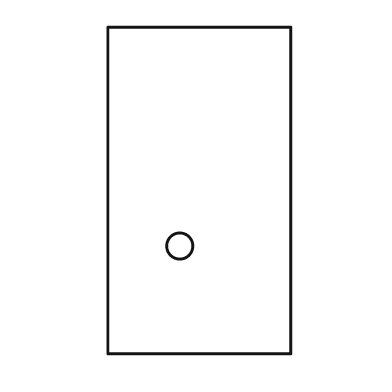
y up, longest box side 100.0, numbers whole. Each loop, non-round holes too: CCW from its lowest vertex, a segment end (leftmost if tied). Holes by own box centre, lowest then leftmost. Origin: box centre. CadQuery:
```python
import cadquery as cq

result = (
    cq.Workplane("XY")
    .moveTo(-28.0, -50.0)
    .lineTo(28.0, -50.0)
    .lineTo(28.0, 50.0)
    .lineTo(-28.0, 50.0)
    .close()
    .moveTo(-6.0, -17.0)
    .circle(4.0)
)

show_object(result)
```